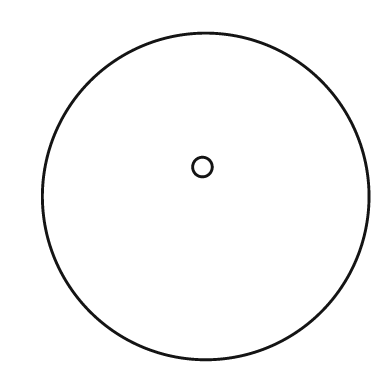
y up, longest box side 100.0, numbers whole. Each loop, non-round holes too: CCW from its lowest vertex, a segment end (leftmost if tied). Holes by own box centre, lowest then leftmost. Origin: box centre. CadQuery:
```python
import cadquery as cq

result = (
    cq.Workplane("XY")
    .moveTo(0.0, 0.0)
    .circle(50.0)
    .moveTo(-1.0, 9.0)
    .circle(3.0)
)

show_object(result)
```